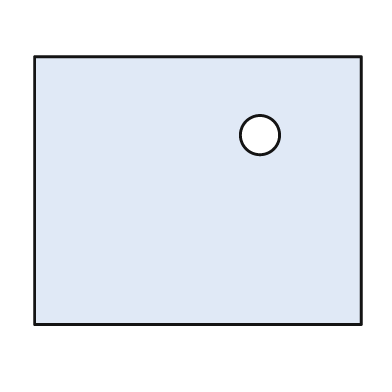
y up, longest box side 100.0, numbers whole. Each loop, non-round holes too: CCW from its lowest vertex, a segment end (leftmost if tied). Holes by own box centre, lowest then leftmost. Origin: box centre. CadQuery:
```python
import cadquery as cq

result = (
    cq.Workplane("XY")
    .moveTo(-50.0, -41.0)
    .lineTo(50.0, -41.0)
    .lineTo(50.0, 41.0)
    .lineTo(-50.0, 41.0)
    .close()
    .moveTo(19.0, 17.0)
    .circle(6.0)
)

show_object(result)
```